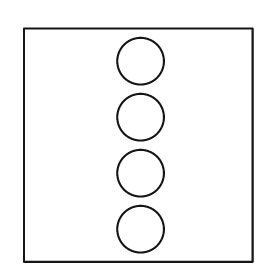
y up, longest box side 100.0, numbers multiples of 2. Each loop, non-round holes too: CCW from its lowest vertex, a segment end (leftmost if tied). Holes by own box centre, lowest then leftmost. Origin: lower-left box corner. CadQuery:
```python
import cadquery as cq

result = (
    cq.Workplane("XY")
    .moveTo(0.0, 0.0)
    .lineTo(98.0, 0.0)
    .lineTo(98.0, 100.0)
    .lineTo(0.0, 100.0)
    .close()
    .moveTo(50.0, 14.0)
    .circle(10.0)
    .moveTo(50.0, 38.0)
    .circle(10.0)
    .moveTo(50.0, 62.0)
    .circle(10.0)
    .moveTo(50.0, 86.0)
    .circle(10.0)
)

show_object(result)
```